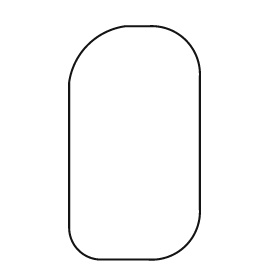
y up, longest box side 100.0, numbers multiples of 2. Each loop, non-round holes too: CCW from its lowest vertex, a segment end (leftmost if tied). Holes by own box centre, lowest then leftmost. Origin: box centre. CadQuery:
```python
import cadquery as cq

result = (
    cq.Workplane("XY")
    .moveTo(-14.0, -50.0)
    .lineTo(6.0, -50.0)
    .threePointArc((22.0, -44.0), (28.0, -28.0))
    .lineTo(28.0, 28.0)
    .threePointArc((22.0, 44.0), (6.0, 50.0))
    .lineTo(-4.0, 50.0)
    .threePointArc((-20.0, 42.0), (-28.0, 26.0))
    .lineTo(-28.0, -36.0)
    .threePointArc((-24.0, -46.0), (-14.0, -50.0))
    .close()
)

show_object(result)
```